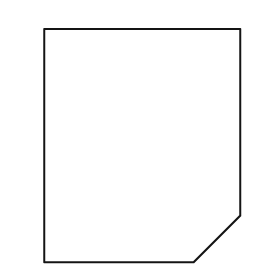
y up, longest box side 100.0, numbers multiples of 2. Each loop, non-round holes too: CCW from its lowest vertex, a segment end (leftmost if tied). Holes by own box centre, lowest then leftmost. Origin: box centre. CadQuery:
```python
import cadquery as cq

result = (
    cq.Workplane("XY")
    .moveTo(-42.0, -50.0)
    .lineTo(22.0, -50.0)
    .lineTo(42.0, -30.0)
    .lineTo(42.0, 50.0)
    .lineTo(-42.0, 50.0)
    .close()
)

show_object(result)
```